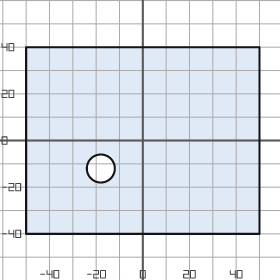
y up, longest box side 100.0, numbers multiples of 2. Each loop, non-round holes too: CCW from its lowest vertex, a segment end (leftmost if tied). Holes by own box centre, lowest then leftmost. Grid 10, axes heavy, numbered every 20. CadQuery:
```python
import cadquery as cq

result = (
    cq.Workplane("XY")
    .moveTo(-50.0, -40.0)
    .lineTo(50.0, -40.0)
    .lineTo(50.0, 40.0)
    .lineTo(-50.0, 40.0)
    .close()
    .moveTo(-18.0, -12.0)
    .circle(6.0)
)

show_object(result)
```